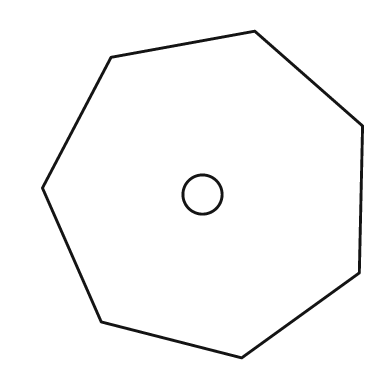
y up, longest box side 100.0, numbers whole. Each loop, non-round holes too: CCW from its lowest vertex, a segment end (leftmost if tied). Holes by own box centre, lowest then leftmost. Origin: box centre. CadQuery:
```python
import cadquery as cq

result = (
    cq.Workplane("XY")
    .moveTo(12.0, -50.0)
    .lineTo(48.0, -24.0)
    .lineTo(49.0, 21.0)
    .lineTo(16.0, 50.0)
    .lineTo(-28.0, 42.0)
    .lineTo(-49.0, 2.0)
    .lineTo(-31.0, -39.0)
    .close()
    .moveTo(0.0, 0.0)
    .circle(6.0)
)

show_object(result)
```